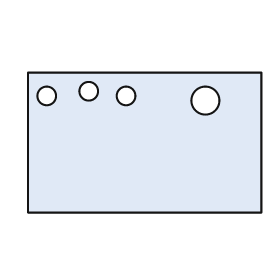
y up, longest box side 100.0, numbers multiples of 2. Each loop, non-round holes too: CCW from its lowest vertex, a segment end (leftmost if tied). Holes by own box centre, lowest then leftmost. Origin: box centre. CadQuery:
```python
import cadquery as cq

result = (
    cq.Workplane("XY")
    .moveTo(-50.0, -30.0)
    .lineTo(50.0, -30.0)
    .lineTo(50.0, 30.0)
    .lineTo(-50.0, 30.0)
    .close()
    .moveTo(26.0, 18.0)
    .circle(6.0)
    .moveTo(-42.0, 20.0)
    .circle(4.0)
    .moveTo(-8.0, 20.0)
    .circle(4.0)
    .moveTo(-24.0, 22.0)
    .circle(4.0)
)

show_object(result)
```